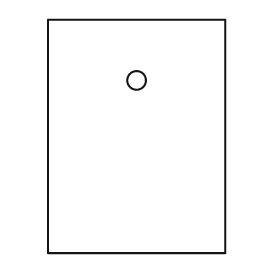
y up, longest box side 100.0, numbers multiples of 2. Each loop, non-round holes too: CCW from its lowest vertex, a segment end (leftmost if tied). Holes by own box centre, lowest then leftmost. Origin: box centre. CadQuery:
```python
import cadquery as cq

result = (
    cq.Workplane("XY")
    .moveTo(-38.0, -50.0)
    .lineTo(38.0, -50.0)
    .lineTo(38.0, 50.0)
    .lineTo(-38.0, 50.0)
    .close()
    .moveTo(0.0, 24.0)
    .circle(4.0)
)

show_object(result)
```